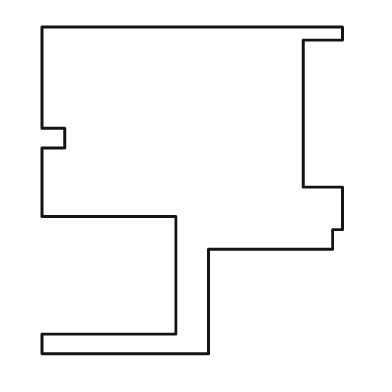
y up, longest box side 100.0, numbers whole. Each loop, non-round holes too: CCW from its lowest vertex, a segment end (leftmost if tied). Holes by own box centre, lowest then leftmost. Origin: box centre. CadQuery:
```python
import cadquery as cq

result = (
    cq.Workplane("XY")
    .moveTo(-46.0, -50.0)
    .lineTo(5.0, -50.0)
    .lineTo(5.0, -18.0)
    .lineTo(43.0, -18.0)
    .lineTo(43.0, -12.0)
    .lineTo(46.0, -12.0)
    .lineTo(46.0, 1.0)
    .lineTo(34.0, 1.0)
    .lineTo(34.0, 46.0)
    .lineTo(46.0, 46.0)
    .lineTo(46.0, 50.0)
    .lineTo(-46.0, 50.0)
    .lineTo(-46.0, 19.0)
    .lineTo(-39.0, 19.0)
    .lineTo(-39.0, 13.0)
    .lineTo(-46.0, 13.0)
    .lineTo(-46.0, -8.0)
    .lineTo(-5.0, -8.0)
    .lineTo(-5.0, -44.0)
    .lineTo(-46.0, -44.0)
    .close()
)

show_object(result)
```